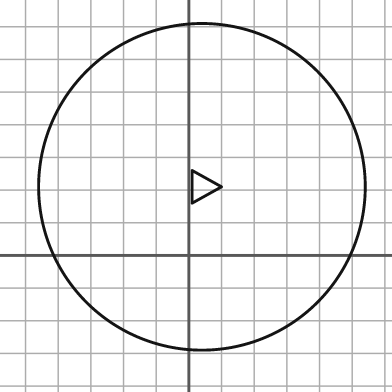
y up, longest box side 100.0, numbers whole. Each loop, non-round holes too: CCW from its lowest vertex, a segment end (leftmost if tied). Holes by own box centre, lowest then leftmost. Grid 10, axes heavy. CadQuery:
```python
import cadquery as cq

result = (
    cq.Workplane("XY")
    .moveTo(4.0, 21.0)
    .circle(50.0)
    .moveTo(1.0, 16.0)
    .lineTo(10.0, 21.0)
    .lineTo(1.0, 26.0)
    .close()
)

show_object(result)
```